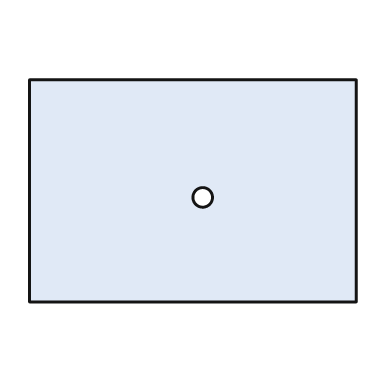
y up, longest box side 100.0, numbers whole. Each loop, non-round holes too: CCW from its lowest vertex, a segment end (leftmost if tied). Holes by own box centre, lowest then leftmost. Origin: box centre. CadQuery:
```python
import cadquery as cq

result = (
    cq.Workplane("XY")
    .moveTo(-50.0, -34.0)
    .lineTo(50.0, -34.0)
    .lineTo(50.0, 34.0)
    .lineTo(-50.0, 34.0)
    .close()
    .moveTo(3.0, -2.0)
    .circle(3.0)
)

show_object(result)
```